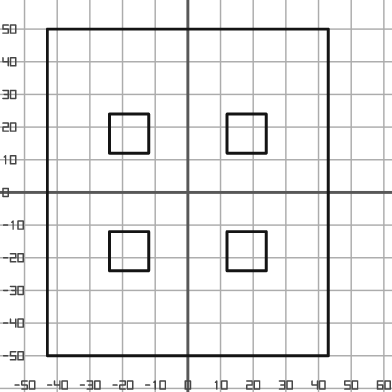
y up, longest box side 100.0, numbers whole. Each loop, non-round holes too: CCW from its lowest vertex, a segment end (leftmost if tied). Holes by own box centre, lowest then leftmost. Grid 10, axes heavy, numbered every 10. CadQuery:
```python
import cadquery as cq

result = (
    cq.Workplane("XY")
    .moveTo(-43.0, -50.0)
    .lineTo(43.0, -50.0)
    .lineTo(43.0, 50.0)
    .lineTo(-43.0, 50.0)
    .close()
    .moveTo(-24.0, -24.0)
    .lineTo(-12.0, -24.0)
    .lineTo(-12.0, -12.0)
    .lineTo(-24.0, -12.0)
    .close()
    .moveTo(12.0, -24.0)
    .lineTo(24.0, -24.0)
    .lineTo(24.0, -12.0)
    .lineTo(12.0, -12.0)
    .close()
    .moveTo(-24.0, 12.0)
    .lineTo(-12.0, 12.0)
    .lineTo(-12.0, 24.0)
    .lineTo(-24.0, 24.0)
    .close()
    .moveTo(12.0, 12.0)
    .lineTo(24.0, 12.0)
    .lineTo(24.0, 24.0)
    .lineTo(12.0, 24.0)
    .close()
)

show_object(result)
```